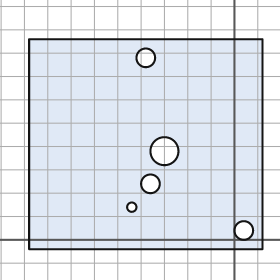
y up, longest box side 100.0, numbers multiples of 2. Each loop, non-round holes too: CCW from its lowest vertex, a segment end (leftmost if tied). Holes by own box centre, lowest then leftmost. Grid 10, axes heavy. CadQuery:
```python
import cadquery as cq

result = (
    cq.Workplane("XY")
    .moveTo(-88.0, -4.0)
    .lineTo(12.0, -4.0)
    .lineTo(12.0, 86.0)
    .lineTo(-88.0, 86.0)
    .close()
    .moveTo(4.0, 4.0)
    .circle(4.0)
    .moveTo(-44.0, 14.0)
    .circle(2.0)
    .moveTo(-36.0, 24.0)
    .circle(4.0)
    .moveTo(-30.0, 38.0)
    .circle(6.0)
    .moveTo(-38.0, 78.0)
    .circle(4.0)
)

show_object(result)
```